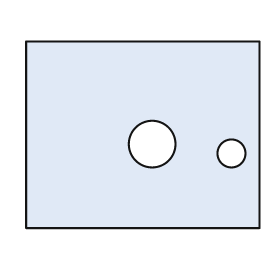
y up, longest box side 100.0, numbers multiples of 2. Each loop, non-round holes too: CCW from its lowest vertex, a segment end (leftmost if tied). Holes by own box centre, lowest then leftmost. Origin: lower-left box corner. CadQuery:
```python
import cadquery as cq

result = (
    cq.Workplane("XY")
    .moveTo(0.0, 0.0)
    .lineTo(100.0, 0.0)
    .lineTo(100.0, 80.0)
    .lineTo(0.0, 80.0)
    .close()
    .moveTo(88.0, 32.0)
    .circle(6.0)
    .moveTo(54.0, 36.0)
    .circle(10.0)
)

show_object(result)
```